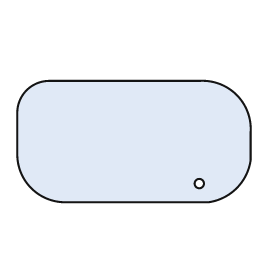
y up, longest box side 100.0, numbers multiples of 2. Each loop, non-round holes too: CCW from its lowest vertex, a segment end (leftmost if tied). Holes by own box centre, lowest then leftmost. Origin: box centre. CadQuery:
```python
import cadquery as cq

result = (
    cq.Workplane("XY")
    .moveTo(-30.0, -26.0)
    .lineTo(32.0, -26.0)
    .threePointArc((44.0, -20.0), (50.0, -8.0))
    .lineTo(50.0, 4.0)
    .threePointArc((44.0, 20.0), (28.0, 26.0))
    .lineTo(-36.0, 26.0)
    .threePointArc((-46.0, 22.0), (-50.0, 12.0))
    .lineTo(-50.0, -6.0)
    .threePointArc((-44.0, -20.0), (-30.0, -26.0))
    .close()
    .moveTo(28.0, -18.0)
    .circle(2.0)
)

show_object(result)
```